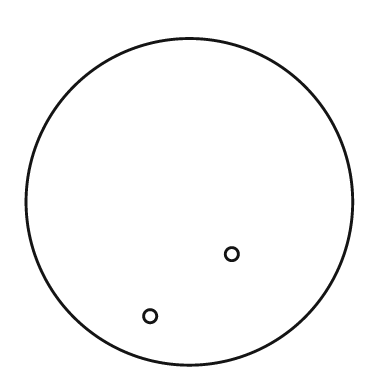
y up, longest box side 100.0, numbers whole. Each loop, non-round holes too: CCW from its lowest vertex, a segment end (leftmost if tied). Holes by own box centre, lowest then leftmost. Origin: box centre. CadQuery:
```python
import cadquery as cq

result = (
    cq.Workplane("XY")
    .moveTo(0.0, 0.0)
    .circle(50.0)
    .moveTo(-12.0, -35.0)
    .circle(2.0)
    .moveTo(13.0, -16.0)
    .circle(2.0)
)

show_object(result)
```